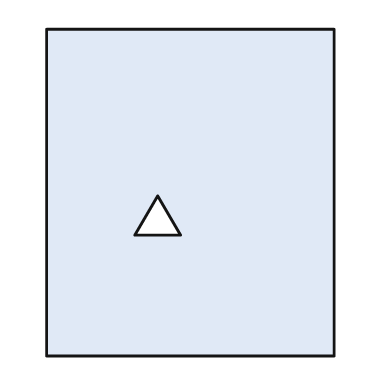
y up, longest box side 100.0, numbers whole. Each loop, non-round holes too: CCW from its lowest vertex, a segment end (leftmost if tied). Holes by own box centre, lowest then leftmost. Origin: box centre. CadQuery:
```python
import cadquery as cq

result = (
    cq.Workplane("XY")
    .moveTo(-44.0, -50.0)
    .lineTo(44.0, -50.0)
    .lineTo(44.0, 50.0)
    .lineTo(-44.0, 50.0)
    .close()
    .moveTo(-17.0, -13.0)
    .lineTo(-3.0, -13.0)
    .lineTo(-10.0, -1.0)
    .close()
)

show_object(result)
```